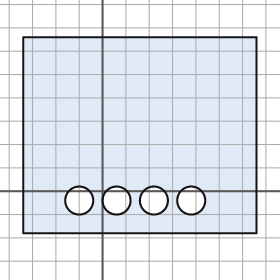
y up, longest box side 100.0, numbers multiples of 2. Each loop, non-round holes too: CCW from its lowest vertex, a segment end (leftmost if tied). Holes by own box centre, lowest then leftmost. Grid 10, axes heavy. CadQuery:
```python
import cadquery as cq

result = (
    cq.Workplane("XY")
    .moveTo(-34.0, -18.0)
    .lineTo(66.0, -18.0)
    .lineTo(66.0, 66.0)
    .lineTo(-34.0, 66.0)
    .close()
    .moveTo(-10.0, -4.0)
    .circle(6.0)
    .moveTo(6.0, -4.0)
    .circle(6.0)
    .moveTo(22.0, -4.0)
    .circle(6.0)
    .moveTo(38.0, -4.0)
    .circle(6.0)
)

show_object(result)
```